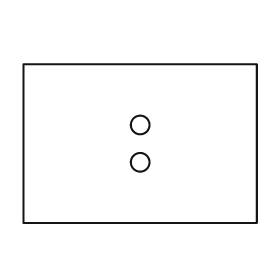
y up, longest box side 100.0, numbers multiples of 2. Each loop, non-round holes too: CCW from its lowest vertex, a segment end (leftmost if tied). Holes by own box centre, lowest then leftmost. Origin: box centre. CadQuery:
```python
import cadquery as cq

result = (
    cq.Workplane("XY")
    .moveTo(-50.0, -34.0)
    .lineTo(50.0, -34.0)
    .lineTo(50.0, 34.0)
    .lineTo(-50.0, 34.0)
    .close()
    .moveTo(0.0, -8.0)
    .circle(4.0)
    .moveTo(0.0, 8.0)
    .circle(4.0)
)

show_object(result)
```